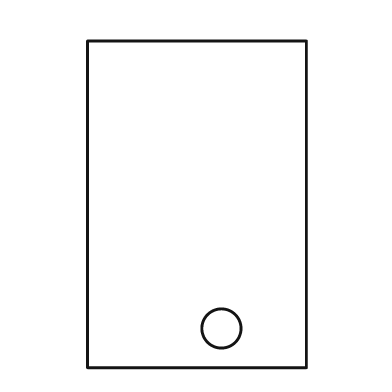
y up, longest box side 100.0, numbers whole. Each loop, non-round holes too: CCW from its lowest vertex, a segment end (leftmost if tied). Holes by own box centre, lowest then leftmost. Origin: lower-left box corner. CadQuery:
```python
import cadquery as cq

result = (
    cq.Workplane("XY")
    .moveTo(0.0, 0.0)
    .lineTo(67.0, 0.0)
    .lineTo(67.0, 100.0)
    .lineTo(0.0, 100.0)
    .close()
    .moveTo(41.0, 12.0)
    .circle(6.0)
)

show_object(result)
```